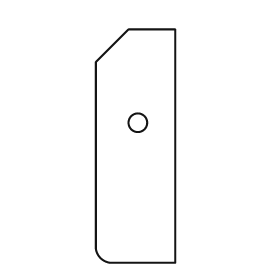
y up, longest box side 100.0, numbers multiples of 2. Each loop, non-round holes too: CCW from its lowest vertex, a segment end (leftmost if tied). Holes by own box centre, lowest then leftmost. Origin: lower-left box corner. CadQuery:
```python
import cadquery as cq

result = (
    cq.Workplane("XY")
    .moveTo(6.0, 0.0)
    .lineTo(34.0, 0.0)
    .lineTo(34.0, 100.0)
    .lineTo(14.0, 100.0)
    .lineTo(0.0, 86.0)
    .lineTo(0.0, 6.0)
    .threePointArc((2.0, 2.0), (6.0, 0.0))
    .close()
    .moveTo(18.0, 60.0)
    .circle(4.0)
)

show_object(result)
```